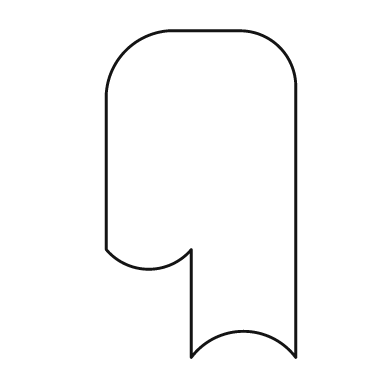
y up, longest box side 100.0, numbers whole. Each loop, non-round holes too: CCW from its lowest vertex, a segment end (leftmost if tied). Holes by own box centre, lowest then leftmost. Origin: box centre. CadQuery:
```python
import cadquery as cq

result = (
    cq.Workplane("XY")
    .moveTo(-3.0, -50.0)
    .threePointArc((13.0, -42.0), (29.0, -50.0))
    .lineTo(29.0, 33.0)
    .threePointArc((24.0, 45.0), (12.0, 50.0))
    .lineTo(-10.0, 50.0)
    .threePointArc((-23.0, 44.0), (-29.0, 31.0))
    .lineTo(-29.0, -17.0)
    .threePointArc((-16.0, -23.0), (-3.0, -17.0))
    .close()
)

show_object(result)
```